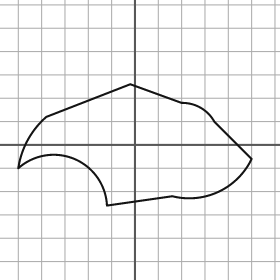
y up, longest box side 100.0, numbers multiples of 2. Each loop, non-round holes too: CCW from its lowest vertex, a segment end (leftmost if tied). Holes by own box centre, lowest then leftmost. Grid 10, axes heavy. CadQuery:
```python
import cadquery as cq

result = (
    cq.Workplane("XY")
    .moveTo(-12.0, -26.0)
    .lineTo(16.0, -22.0)
    .threePointArc((36.0, -20.0), (50.0, -6.0))
    .lineTo(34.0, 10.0)
    .threePointArc((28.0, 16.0), (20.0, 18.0))
    .lineTo(-2.0, 26.0)
    .lineTo(-38.0, 12.0)
    .threePointArc((-46.0, 2.0), (-50.0, -10.0))
    .threePointArc((-26.0, -6.0), (-12.0, -26.0))
    .close()
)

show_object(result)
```